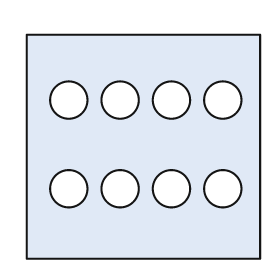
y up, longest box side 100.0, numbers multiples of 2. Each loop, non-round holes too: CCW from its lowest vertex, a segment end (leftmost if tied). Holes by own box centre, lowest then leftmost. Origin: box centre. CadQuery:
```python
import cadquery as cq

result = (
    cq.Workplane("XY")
    .moveTo(-50.0, -48.0)
    .lineTo(50.0, -48.0)
    .lineTo(50.0, 48.0)
    .lineTo(-50.0, 48.0)
    .close()
    .moveTo(-32.0, -18.0)
    .circle(8.0)
    .moveTo(-10.0, -18.0)
    .circle(8.0)
    .moveTo(12.0, -18.0)
    .circle(8.0)
    .moveTo(34.0, -18.0)
    .circle(8.0)
    .moveTo(-32.0, 20.0)
    .circle(8.0)
    .moveTo(-10.0, 20.0)
    .circle(8.0)
    .moveTo(12.0, 20.0)
    .circle(8.0)
    .moveTo(34.0, 20.0)
    .circle(8.0)
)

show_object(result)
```